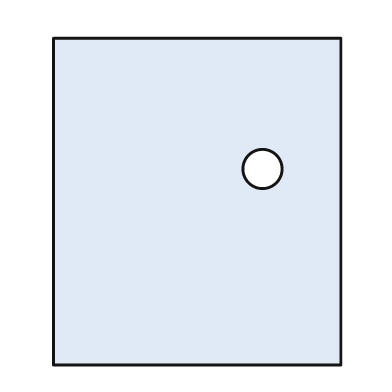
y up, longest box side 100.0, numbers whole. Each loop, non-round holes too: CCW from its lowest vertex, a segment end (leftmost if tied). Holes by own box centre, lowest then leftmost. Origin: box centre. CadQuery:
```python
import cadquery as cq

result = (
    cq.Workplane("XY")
    .moveTo(-44.0, -50.0)
    .lineTo(44.0, -50.0)
    .lineTo(44.0, 50.0)
    .lineTo(-44.0, 50.0)
    .close()
    .moveTo(20.0, 10.0)
    .circle(6.0)
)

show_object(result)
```